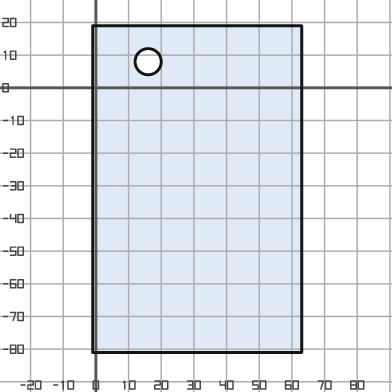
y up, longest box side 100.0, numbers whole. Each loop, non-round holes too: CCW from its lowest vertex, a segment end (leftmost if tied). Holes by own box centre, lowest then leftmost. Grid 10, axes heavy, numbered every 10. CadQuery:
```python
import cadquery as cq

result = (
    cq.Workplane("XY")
    .moveTo(-1.0, -81.0)
    .lineTo(63.0, -81.0)
    .lineTo(63.0, 19.0)
    .lineTo(-1.0, 19.0)
    .close()
    .moveTo(16.0, 8.0)
    .circle(4.0)
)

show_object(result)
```